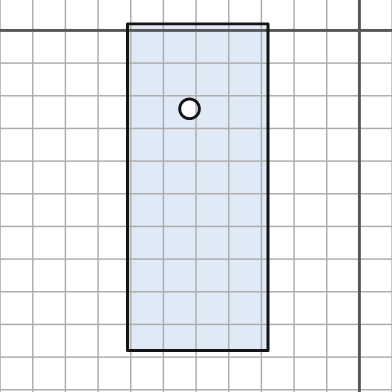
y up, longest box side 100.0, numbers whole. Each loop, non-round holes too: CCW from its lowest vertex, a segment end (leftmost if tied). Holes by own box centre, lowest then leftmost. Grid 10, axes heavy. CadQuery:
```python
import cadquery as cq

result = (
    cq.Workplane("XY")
    .moveTo(-71.0, -98.0)
    .lineTo(-28.0, -98.0)
    .lineTo(-28.0, 2.0)
    .lineTo(-71.0, 2.0)
    .close()
    .moveTo(-52.0, -24.0)
    .circle(3.0)
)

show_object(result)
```